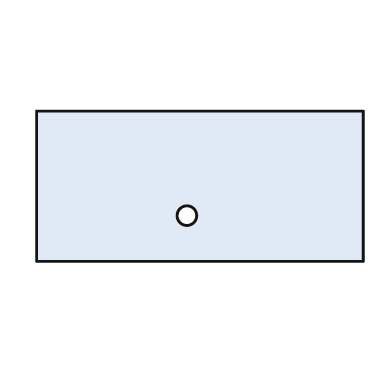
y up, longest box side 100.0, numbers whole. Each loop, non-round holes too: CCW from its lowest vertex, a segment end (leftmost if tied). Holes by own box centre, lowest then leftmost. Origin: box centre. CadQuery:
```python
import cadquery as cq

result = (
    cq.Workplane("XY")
    .moveTo(-50.0, -23.0)
    .lineTo(50.0, -23.0)
    .lineTo(50.0, 23.0)
    .lineTo(-50.0, 23.0)
    .close()
    .moveTo(-4.0, -9.0)
    .circle(3.0)
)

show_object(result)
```